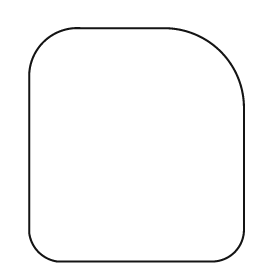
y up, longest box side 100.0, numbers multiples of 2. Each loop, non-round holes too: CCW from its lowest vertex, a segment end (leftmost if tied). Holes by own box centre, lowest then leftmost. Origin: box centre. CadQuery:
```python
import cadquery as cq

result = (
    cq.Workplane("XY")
    .moveTo(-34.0, -50.0)
    .lineTo(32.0, -50.0)
    .threePointArc((42.0, -46.0), (46.0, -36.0))
    .lineTo(46.0, 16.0)
    .threePointArc((36.0, 40.0), (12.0, 50.0))
    .lineTo(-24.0, 50.0)
    .threePointArc((-40.0, 44.0), (-46.0, 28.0))
    .lineTo(-46.0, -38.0)
    .threePointArc((-42.0, -46.0), (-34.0, -50.0))
    .close()
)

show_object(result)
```